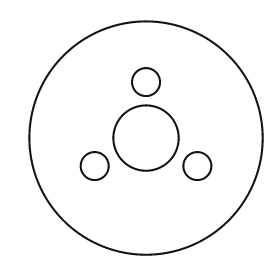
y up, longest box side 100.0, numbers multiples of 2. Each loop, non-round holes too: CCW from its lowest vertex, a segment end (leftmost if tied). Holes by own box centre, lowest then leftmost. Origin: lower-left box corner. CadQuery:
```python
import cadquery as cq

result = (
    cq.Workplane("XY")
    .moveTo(50.0, 50.0)
    .circle(50.0)
    .moveTo(28.0, 38.0)
    .circle(6.0)
    .moveTo(72.0, 38.0)
    .circle(6.0)
    .moveTo(50.0, 50.0)
    .circle(14.0)
    .moveTo(50.0, 74.0)
    .circle(6.0)
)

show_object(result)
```